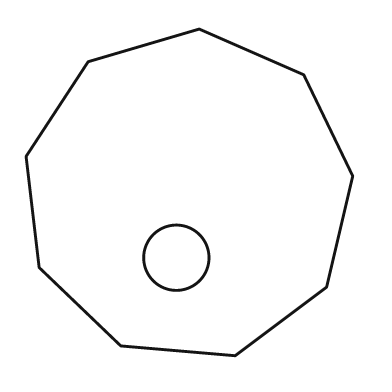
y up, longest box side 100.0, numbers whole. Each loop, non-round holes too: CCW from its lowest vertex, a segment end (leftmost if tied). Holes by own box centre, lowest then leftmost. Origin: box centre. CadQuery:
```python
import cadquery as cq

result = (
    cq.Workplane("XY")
    .moveTo(14.0, -50.0)
    .lineTo(42.0, -29.0)
    .lineTo(50.0, 5.0)
    .lineTo(35.0, 36.0)
    .lineTo(3.0, 50.0)
    .lineTo(-31.0, 40.0)
    .lineTo(-50.0, 11.0)
    .lineTo(-46.0, -23.0)
    .lineTo(-21.0, -47.0)
    .close()
    .moveTo(-4.0, -20.0)
    .circle(10.0)
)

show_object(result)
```